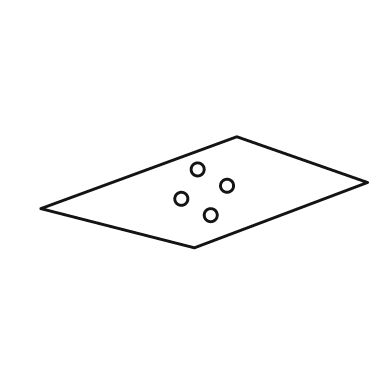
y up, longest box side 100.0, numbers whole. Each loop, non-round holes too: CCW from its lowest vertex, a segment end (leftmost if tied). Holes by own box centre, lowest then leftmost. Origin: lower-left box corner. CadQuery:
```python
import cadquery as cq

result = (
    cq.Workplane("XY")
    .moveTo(47.0, 0.0)
    .lineTo(100.0, 20.0)
    .lineTo(60.0, 34.0)
    .lineTo(0.0, 12.0)
    .close()
    .moveTo(52.0, 10.0)
    .circle(2.0)
    .moveTo(43.0, 15.0)
    .circle(2.0)
    .moveTo(57.0, 19.0)
    .circle(2.0)
    .moveTo(48.0, 24.0)
    .circle(2.0)
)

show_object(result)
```